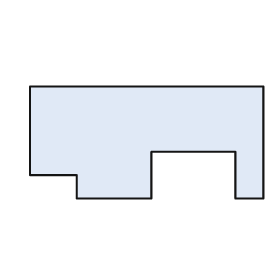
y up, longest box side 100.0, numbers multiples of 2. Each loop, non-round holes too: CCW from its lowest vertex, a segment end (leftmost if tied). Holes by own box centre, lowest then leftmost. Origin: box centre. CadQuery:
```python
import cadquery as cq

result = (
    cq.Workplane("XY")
    .moveTo(-30.0, -24.0)
    .lineTo(2.0, -24.0)
    .lineTo(2.0, -4.0)
    .lineTo(38.0, -4.0)
    .lineTo(38.0, -24.0)
    .lineTo(50.0, -24.0)
    .lineTo(50.0, 24.0)
    .lineTo(-50.0, 24.0)
    .lineTo(-50.0, -14.0)
    .lineTo(-30.0, -14.0)
    .close()
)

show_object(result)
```